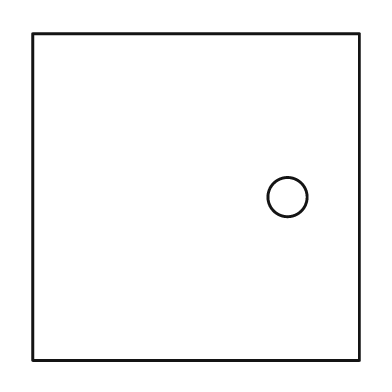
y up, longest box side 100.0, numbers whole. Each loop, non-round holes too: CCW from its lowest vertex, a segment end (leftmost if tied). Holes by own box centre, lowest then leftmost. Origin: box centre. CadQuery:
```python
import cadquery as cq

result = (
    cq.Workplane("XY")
    .moveTo(-50.0, -50.0)
    .lineTo(50.0, -50.0)
    .lineTo(50.0, 50.0)
    .lineTo(-50.0, 50.0)
    .close()
    .moveTo(28.0, 0.0)
    .circle(6.0)
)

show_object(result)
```